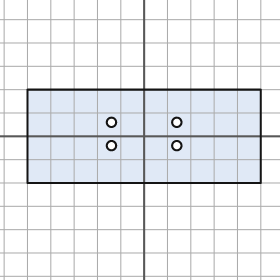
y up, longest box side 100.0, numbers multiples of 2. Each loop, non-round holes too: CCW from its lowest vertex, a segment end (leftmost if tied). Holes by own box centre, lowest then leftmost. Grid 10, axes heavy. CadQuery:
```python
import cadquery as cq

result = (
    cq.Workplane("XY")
    .moveTo(-50.0, -20.0)
    .lineTo(50.0, -20.0)
    .lineTo(50.0, 20.0)
    .lineTo(-50.0, 20.0)
    .close()
    .moveTo(-14.0, -4.0)
    .circle(2.0)
    .moveTo(14.0, -4.0)
    .circle(2.0)
    .moveTo(-14.0, 6.0)
    .circle(2.0)
    .moveTo(14.0, 6.0)
    .circle(2.0)
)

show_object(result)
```